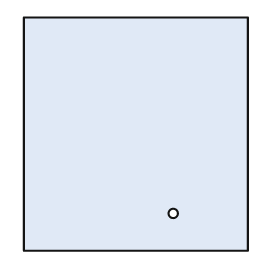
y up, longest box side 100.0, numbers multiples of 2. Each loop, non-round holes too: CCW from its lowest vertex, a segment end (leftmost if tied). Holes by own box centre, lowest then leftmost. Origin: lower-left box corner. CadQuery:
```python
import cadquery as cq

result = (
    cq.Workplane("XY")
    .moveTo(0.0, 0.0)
    .lineTo(96.0, 0.0)
    .lineTo(96.0, 100.0)
    .lineTo(0.0, 100.0)
    .close()
    .moveTo(64.0, 16.0)
    .circle(2.0)
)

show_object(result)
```